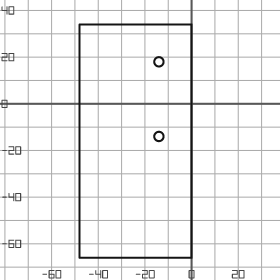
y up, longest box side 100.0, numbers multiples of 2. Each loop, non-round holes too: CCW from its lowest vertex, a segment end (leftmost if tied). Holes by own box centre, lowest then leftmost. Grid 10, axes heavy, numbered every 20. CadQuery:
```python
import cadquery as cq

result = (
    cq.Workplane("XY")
    .moveTo(-48.0, -66.0)
    .lineTo(0.0, -66.0)
    .lineTo(0.0, 34.0)
    .lineTo(-48.0, 34.0)
    .close()
    .moveTo(-14.0, -14.0)
    .circle(2.0)
    .moveTo(-14.0, 18.0)
    .circle(2.0)
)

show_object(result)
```